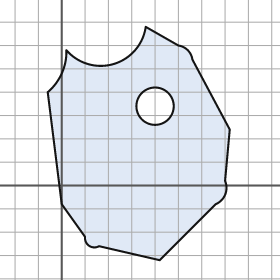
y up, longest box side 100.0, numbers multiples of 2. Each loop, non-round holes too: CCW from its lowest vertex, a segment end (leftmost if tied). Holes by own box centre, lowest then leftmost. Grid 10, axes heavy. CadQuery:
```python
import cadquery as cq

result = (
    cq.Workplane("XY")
    .moveTo(42.0, -32.0)
    .lineTo(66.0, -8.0)
    .threePointArc((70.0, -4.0), (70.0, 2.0))
    .lineTo(72.0, 24.0)
    .lineTo(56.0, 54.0)
    .threePointArc((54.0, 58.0), (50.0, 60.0))
    .lineTo(36.0, 68.0)
    .threePointArc((22.0, 52.0), (2.0, 58.0))
    .threePointArc((0.0, 48.0), (-6.0, 40.0))
    .lineTo(0.0, -8.0)
    .lineTo(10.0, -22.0)
    .threePointArc((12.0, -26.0), (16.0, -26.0))
    .close()
    .moveTo(40.0, 34.0)
    .circle(8.0)
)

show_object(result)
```